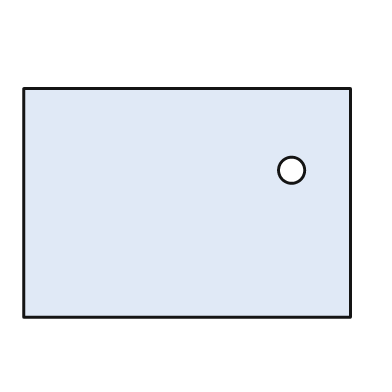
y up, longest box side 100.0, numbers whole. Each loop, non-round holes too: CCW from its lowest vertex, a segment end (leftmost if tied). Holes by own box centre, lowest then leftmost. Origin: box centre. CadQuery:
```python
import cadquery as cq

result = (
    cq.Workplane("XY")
    .moveTo(-50.0, -35.0)
    .lineTo(50.0, -35.0)
    .lineTo(50.0, 35.0)
    .lineTo(-50.0, 35.0)
    .close()
    .moveTo(32.0, 10.0)
    .circle(4.0)
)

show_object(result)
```